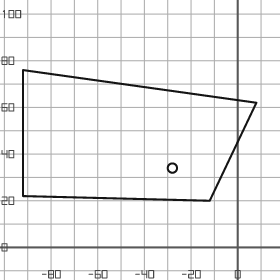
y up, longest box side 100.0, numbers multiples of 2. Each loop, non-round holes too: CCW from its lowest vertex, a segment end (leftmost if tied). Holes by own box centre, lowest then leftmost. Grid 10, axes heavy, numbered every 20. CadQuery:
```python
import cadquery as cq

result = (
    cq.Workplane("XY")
    .moveTo(-12.0, 20.0)
    .lineTo(8.0, 62.0)
    .lineTo(-92.0, 76.0)
    .lineTo(-92.0, 22.0)
    .close()
    .moveTo(-28.0, 34.0)
    .circle(2.0)
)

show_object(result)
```